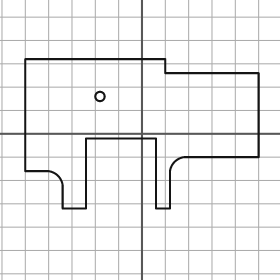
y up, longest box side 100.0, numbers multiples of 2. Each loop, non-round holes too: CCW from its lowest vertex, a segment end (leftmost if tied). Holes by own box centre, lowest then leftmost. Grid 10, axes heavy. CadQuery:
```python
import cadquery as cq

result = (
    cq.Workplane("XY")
    .moveTo(-34.0, -32.0)
    .lineTo(-24.0, -32.0)
    .lineTo(-24.0, -2.0)
    .lineTo(6.0, -2.0)
    .lineTo(6.0, -32.0)
    .lineTo(12.0, -32.0)
    .lineTo(12.0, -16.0)
    .threePointArc((14.0, -12.0), (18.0, -10.0))
    .lineTo(50.0, -10.0)
    .lineTo(50.0, 26.0)
    .lineTo(10.0, 26.0)
    .lineTo(10.0, 32.0)
    .lineTo(-50.0, 32.0)
    .lineTo(-50.0, -16.0)
    .lineTo(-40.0, -16.0)
    .threePointArc((-36.0, -18.0), (-34.0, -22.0))
    .close()
    .moveTo(-18.0, 16.0)
    .circle(2.0)
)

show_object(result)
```